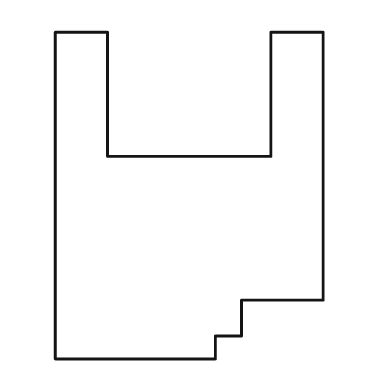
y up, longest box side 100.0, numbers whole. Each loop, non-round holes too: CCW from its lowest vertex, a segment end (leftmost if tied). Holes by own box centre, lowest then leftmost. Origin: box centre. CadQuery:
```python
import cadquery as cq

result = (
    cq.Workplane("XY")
    .moveTo(-41.0, -50.0)
    .lineTo(8.0, -50.0)
    .lineTo(8.0, -43.0)
    .lineTo(16.0, -43.0)
    .lineTo(16.0, -32.0)
    .lineTo(41.0, -32.0)
    .lineTo(41.0, 50.0)
    .lineTo(25.0, 50.0)
    .lineTo(25.0, 12.0)
    .lineTo(-25.0, 12.0)
    .lineTo(-25.0, 50.0)
    .lineTo(-41.0, 50.0)
    .close()
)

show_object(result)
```